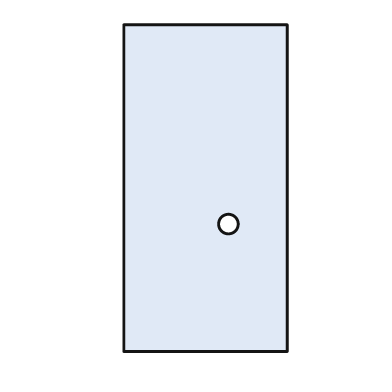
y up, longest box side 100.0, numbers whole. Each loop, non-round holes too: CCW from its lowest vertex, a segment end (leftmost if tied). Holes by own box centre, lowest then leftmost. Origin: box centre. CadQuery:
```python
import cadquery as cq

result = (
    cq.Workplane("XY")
    .moveTo(-25.0, -50.0)
    .lineTo(25.0, -50.0)
    .lineTo(25.0, 50.0)
    .lineTo(-25.0, 50.0)
    .close()
    .moveTo(7.0, -11.0)
    .circle(3.0)
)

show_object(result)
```